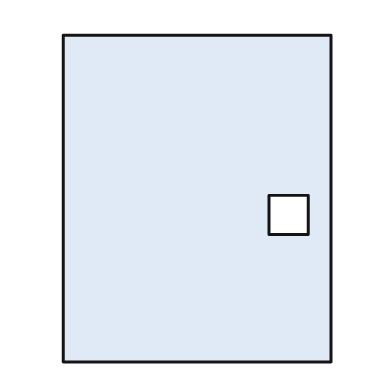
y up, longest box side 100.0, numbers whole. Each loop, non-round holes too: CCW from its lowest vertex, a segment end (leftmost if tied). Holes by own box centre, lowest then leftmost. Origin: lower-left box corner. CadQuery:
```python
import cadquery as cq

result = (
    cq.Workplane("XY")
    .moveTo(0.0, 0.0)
    .lineTo(82.0, 0.0)
    .lineTo(82.0, 100.0)
    .lineTo(0.0, 100.0)
    .close()
    .moveTo(63.0, 39.0)
    .lineTo(75.0, 39.0)
    .lineTo(75.0, 51.0)
    .lineTo(63.0, 51.0)
    .close()
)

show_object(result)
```